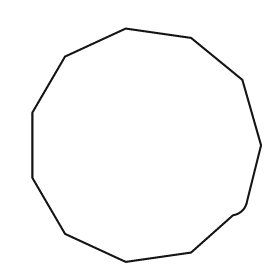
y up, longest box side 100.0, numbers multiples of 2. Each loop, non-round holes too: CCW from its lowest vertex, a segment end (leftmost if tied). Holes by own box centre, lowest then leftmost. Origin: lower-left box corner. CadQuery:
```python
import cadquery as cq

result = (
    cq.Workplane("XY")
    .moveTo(40.0, 0.0)
    .lineTo(68.0, 4.0)
    .lineTo(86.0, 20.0)
    .threePointArc((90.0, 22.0), (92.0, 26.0))
    .lineTo(98.0, 50.0)
    .lineTo(90.0, 78.0)
    .lineTo(68.0, 96.0)
    .lineTo(40.0, 100.0)
    .lineTo(14.0, 88.0)
    .lineTo(0.0, 64.0)
    .lineTo(0.0, 36.0)
    .lineTo(14.0, 12.0)
    .close()
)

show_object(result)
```